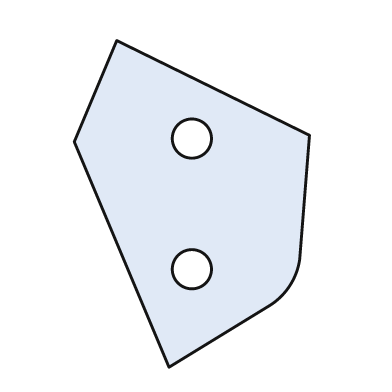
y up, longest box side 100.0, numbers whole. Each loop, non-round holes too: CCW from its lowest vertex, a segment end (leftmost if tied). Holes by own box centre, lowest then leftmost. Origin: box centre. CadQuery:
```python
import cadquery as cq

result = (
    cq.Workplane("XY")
    .moveTo(-7.0, -50.0)
    .lineTo(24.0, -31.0)
    .threePointArc((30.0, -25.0), (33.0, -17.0))
    .lineTo(36.0, 21.0)
    .lineTo(-23.0, 50.0)
    .lineTo(-36.0, 19.0)
    .close()
    .moveTo(0.0, -20.0)
    .circle(6.0)
    .moveTo(0.0, 20.0)
    .circle(6.0)
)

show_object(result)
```